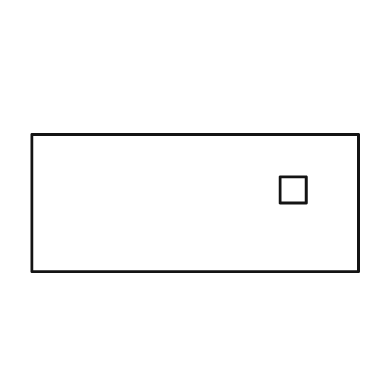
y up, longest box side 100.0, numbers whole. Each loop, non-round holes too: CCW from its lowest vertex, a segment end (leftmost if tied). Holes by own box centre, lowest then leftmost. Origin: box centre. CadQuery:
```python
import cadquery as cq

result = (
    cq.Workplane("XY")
    .moveTo(-50.0, -21.0)
    .lineTo(50.0, -21.0)
    .lineTo(50.0, 21.0)
    .lineTo(-50.0, 21.0)
    .close()
    .moveTo(26.0, 0.0)
    .lineTo(34.0, 0.0)
    .lineTo(34.0, 8.0)
    .lineTo(26.0, 8.0)
    .close()
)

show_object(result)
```